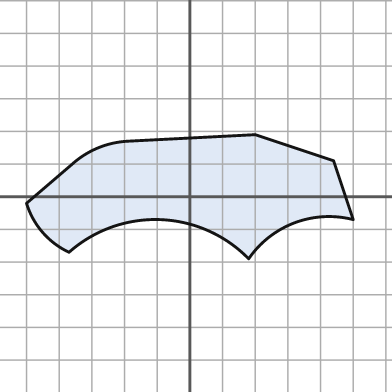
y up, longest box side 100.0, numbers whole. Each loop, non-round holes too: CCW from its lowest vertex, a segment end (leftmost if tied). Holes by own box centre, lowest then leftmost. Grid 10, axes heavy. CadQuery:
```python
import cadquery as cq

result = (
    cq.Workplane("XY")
    .moveTo(18.0, -19.0)
    .threePointArc((32.0, -8.0), (50.0, -7.0))
    .lineTo(44.0, 11.0)
    .lineTo(20.0, 19.0)
    .lineTo(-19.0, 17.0)
    .threePointArc((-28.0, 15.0), (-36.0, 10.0))
    .lineTo(-50.0, -2.0)
    .threePointArc((-45.0, -11.0), (-37.0, -17.0))
    .threePointArc((-9.0, -7.0), (18.0, -19.0))
    .close()
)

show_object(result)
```